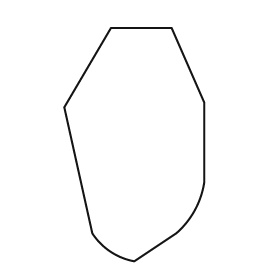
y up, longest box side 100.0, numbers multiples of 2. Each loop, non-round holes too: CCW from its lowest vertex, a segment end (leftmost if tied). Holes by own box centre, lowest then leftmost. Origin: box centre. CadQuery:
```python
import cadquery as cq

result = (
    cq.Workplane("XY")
    .moveTo(0.0, -50.0)
    .lineTo(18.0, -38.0)
    .threePointArc((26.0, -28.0), (30.0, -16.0))
    .lineTo(30.0, 18.0)
    .lineTo(16.0, 50.0)
    .lineTo(-10.0, 50.0)
    .lineTo(-30.0, 16.0)
    .lineTo(-18.0, -38.0)
    .threePointArc((-10.0, -46.0), (0.0, -50.0))
    .close()
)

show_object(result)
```